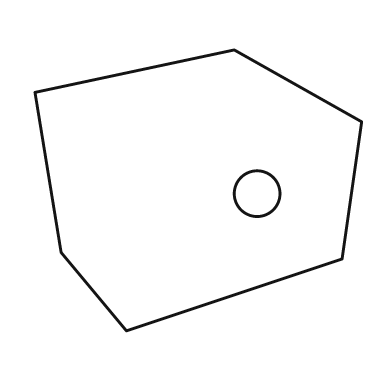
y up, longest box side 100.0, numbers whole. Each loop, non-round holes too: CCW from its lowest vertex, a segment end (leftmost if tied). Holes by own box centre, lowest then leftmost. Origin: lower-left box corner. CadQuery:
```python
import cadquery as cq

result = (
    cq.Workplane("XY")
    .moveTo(28.0, 0.0)
    .lineTo(94.0, 22.0)
    .lineTo(100.0, 64.0)
    .lineTo(61.0, 86.0)
    .lineTo(0.0, 73.0)
    .lineTo(8.0, 24.0)
    .close()
    .moveTo(68.0, 42.0)
    .circle(7.0)
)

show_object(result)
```